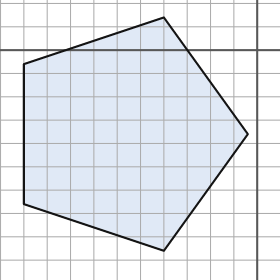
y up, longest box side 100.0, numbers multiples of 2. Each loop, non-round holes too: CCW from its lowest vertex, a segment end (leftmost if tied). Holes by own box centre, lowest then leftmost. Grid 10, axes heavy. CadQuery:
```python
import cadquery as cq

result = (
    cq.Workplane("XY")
    .moveTo(-40.0, -86.0)
    .lineTo(-4.0, -36.0)
    .lineTo(-40.0, 14.0)
    .lineTo(-100.0, -6.0)
    .lineTo(-100.0, -66.0)
    .close()
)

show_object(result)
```